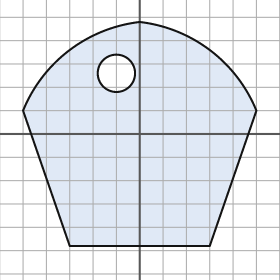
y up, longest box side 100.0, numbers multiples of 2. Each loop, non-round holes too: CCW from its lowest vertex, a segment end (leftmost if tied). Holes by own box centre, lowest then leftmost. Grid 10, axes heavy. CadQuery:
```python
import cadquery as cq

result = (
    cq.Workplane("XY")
    .moveTo(-30.0, -48.0)
    .lineTo(30.0, -48.0)
    .lineTo(50.0, 10.0)
    .threePointArc((30.0, 36.0), (0.0, 48.0))
    .threePointArc((-30.0, 36.0), (-50.0, 10.0))
    .close()
    .moveTo(-10.0, 26.0)
    .circle(8.0)
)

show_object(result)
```